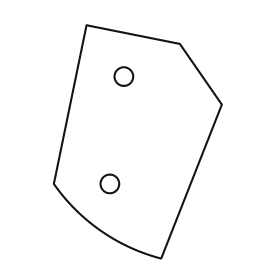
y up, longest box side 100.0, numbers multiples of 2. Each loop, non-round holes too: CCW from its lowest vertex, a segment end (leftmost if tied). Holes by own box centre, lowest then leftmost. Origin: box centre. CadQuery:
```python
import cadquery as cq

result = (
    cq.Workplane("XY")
    .moveTo(10.0, -50.0)
    .lineTo(36.0, 16.0)
    .lineTo(18.0, 42.0)
    .lineTo(-22.0, 50.0)
    .lineTo(-36.0, -18.0)
    .threePointArc((-16.0, -38.0), (10.0, -50.0))
    .close()
    .moveTo(-12.0, -18.0)
    .circle(4.0)
    .moveTo(-6.0, 28.0)
    .circle(4.0)
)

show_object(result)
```